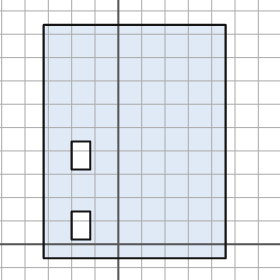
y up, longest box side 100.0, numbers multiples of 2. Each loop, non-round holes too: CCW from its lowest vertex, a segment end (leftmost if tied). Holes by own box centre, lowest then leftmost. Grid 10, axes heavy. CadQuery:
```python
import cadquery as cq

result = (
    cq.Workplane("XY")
    .moveTo(-32.0, -6.0)
    .lineTo(46.0, -6.0)
    .lineTo(46.0, 94.0)
    .lineTo(-32.0, 94.0)
    .close()
    .moveTo(-20.0, 2.0)
    .lineTo(-12.0, 2.0)
    .lineTo(-12.0, 14.0)
    .lineTo(-20.0, 14.0)
    .close()
    .moveTo(-20.0, 32.0)
    .lineTo(-12.0, 32.0)
    .lineTo(-12.0, 44.0)
    .lineTo(-20.0, 44.0)
    .close()
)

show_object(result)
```